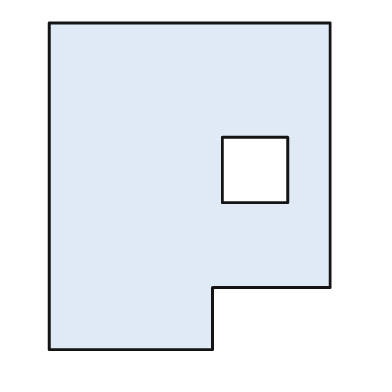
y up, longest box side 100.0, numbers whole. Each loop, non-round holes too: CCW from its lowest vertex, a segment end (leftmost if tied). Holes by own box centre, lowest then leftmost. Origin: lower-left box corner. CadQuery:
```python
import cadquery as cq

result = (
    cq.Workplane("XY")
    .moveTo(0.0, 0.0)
    .lineTo(50.0, 0.0)
    .lineTo(50.0, 19.0)
    .lineTo(86.0, 19.0)
    .lineTo(86.0, 100.0)
    .lineTo(0.0, 100.0)
    .close()
    .moveTo(53.0, 45.0)
    .lineTo(73.0, 45.0)
    .lineTo(73.0, 65.0)
    .lineTo(53.0, 65.0)
    .close()
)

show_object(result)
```